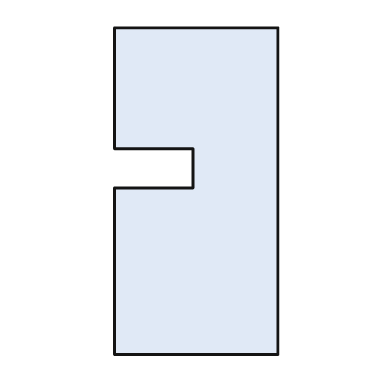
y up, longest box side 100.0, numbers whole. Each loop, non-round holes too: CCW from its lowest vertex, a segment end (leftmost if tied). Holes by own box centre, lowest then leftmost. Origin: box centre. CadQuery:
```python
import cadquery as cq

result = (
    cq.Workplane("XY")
    .moveTo(-25.0, -50.0)
    .lineTo(25.0, -50.0)
    .lineTo(25.0, 50.0)
    .lineTo(-25.0, 50.0)
    .lineTo(-25.0, 13.0)
    .lineTo(-1.0, 13.0)
    .lineTo(-1.0, 1.0)
    .lineTo(-25.0, 1.0)
    .close()
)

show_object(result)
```